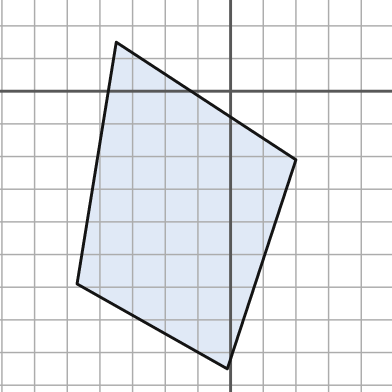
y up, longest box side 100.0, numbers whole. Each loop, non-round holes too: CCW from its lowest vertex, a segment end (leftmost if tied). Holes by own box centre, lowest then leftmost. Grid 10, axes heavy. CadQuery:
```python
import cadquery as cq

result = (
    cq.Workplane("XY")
    .moveTo(-1.0, -85.0)
    .lineTo(20.0, -21.0)
    .lineTo(-35.0, 15.0)
    .lineTo(-47.0, -59.0)
    .close()
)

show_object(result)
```